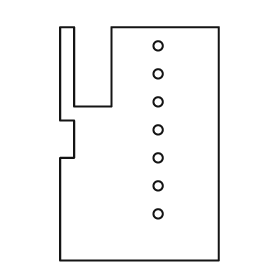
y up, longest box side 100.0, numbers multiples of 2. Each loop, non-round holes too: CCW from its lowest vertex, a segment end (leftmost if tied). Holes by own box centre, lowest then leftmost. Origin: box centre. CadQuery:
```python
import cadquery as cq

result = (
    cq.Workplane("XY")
    .moveTo(-34.0, -50.0)
    .lineTo(34.0, -50.0)
    .lineTo(34.0, 50.0)
    .lineTo(-12.0, 50.0)
    .lineTo(-12.0, 16.0)
    .lineTo(-28.0, 16.0)
    .lineTo(-28.0, 50.0)
    .lineTo(-34.0, 50.0)
    .lineTo(-34.0, 10.0)
    .lineTo(-28.0, 10.0)
    .lineTo(-28.0, -6.0)
    .lineTo(-34.0, -6.0)
    .close()
    .moveTo(8.0, -30.0)
    .circle(2.0)
    .moveTo(8.0, -18.0)
    .circle(2.0)
    .moveTo(8.0, -6.0)
    .circle(2.0)
    .moveTo(8.0, 6.0)
    .circle(2.0)
    .moveTo(8.0, 18.0)
    .circle(2.0)
    .moveTo(8.0, 30.0)
    .circle(2.0)
    .moveTo(8.0, 42.0)
    .circle(2.0)
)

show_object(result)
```